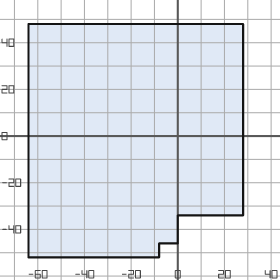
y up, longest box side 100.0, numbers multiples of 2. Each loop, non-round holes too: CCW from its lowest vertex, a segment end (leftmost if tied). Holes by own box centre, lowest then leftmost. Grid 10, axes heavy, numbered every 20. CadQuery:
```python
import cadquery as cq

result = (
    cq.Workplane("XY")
    .moveTo(-64.0, -52.0)
    .lineTo(-8.0, -52.0)
    .lineTo(-8.0, -46.0)
    .lineTo(0.0, -46.0)
    .lineTo(0.0, -34.0)
    .lineTo(28.0, -34.0)
    .lineTo(28.0, 48.0)
    .lineTo(-64.0, 48.0)
    .close()
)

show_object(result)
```